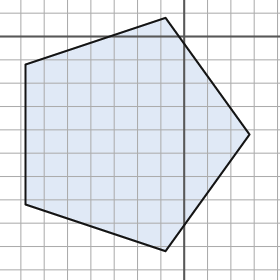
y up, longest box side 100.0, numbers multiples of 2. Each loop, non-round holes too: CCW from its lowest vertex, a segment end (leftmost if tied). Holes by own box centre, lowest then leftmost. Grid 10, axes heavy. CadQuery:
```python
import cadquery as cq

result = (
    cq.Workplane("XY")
    .moveTo(-8.0, -92.0)
    .lineTo(28.0, -42.0)
    .lineTo(-8.0, 8.0)
    .lineTo(-68.0, -12.0)
    .lineTo(-68.0, -72.0)
    .close()
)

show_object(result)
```